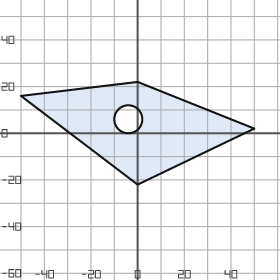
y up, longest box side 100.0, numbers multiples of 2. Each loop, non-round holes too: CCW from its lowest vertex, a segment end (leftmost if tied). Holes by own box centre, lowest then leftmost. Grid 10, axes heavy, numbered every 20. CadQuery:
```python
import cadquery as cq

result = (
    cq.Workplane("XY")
    .moveTo(0.0, -22.0)
    .lineTo(50.0, 2.0)
    .lineTo(0.0, 22.0)
    .lineTo(-50.0, 16.0)
    .close()
    .moveTo(-4.0, 6.0)
    .circle(6.0)
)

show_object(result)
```